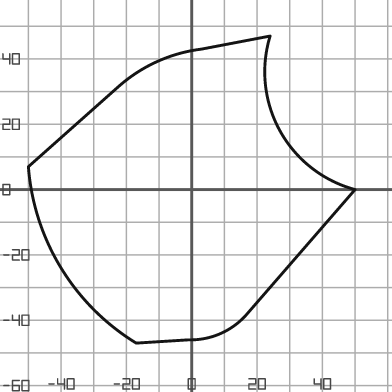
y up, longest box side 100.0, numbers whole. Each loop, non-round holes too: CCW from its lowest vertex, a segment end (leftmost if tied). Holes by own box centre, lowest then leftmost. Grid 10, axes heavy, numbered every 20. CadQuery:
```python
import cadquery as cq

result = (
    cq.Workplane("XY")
    .moveTo(-17.0, -47.0)
    .lineTo(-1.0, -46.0)
    .threePointArc((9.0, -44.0), (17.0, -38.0))
    .lineTo(50.0, 0.0)
    .threePointArc((27.0, 18.0), (24.0, 47.0))
    .lineTo(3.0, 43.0)
    .threePointArc((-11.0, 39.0), (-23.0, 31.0))
    .lineTo(-50.0, 7.0)
    .threePointArc((-40.0, -24.0), (-17.0, -47.0))
    .close()
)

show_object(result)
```